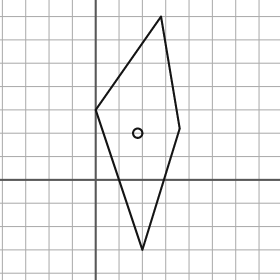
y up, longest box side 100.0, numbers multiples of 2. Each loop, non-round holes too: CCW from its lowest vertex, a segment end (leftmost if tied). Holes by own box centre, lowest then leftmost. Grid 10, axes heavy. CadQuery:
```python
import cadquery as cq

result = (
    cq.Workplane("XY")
    .moveTo(20.0, -30.0)
    .lineTo(36.0, 22.0)
    .lineTo(28.0, 70.0)
    .lineTo(0.0, 30.0)
    .close()
    .moveTo(18.0, 20.0)
    .circle(2.0)
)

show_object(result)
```